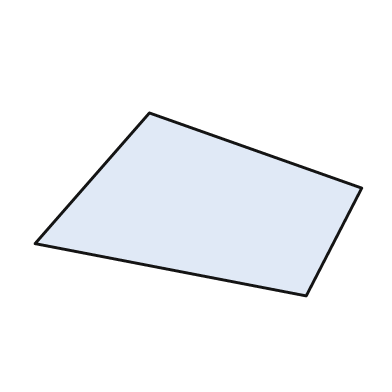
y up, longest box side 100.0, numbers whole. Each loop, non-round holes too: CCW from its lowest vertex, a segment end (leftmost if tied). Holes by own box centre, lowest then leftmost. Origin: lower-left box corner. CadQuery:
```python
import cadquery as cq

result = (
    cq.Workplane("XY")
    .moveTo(83.0, 0.0)
    .lineTo(100.0, 33.0)
    .lineTo(35.0, 56.0)
    .lineTo(0.0, 16.0)
    .close()
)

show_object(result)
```